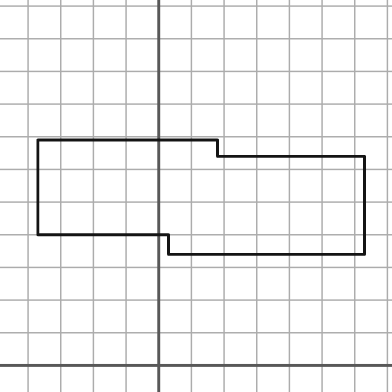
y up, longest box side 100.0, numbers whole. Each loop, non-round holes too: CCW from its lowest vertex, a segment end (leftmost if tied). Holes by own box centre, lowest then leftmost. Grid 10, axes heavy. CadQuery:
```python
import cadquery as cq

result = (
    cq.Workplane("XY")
    .moveTo(3.0, 34.0)
    .lineTo(63.0, 34.0)
    .lineTo(63.0, 64.0)
    .lineTo(18.0, 64.0)
    .lineTo(18.0, 69.0)
    .lineTo(-37.0, 69.0)
    .lineTo(-37.0, 40.0)
    .lineTo(3.0, 40.0)
    .close()
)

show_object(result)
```